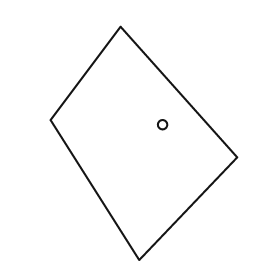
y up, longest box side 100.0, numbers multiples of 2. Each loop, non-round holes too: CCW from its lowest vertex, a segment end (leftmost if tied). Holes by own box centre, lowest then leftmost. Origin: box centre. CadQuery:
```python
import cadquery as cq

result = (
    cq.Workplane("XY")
    .moveTo(-2.0, -50.0)
    .lineTo(40.0, -6.0)
    .lineTo(-10.0, 50.0)
    .lineTo(-40.0, 10.0)
    .close()
    .moveTo(8.0, 8.0)
    .circle(2.0)
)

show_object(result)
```